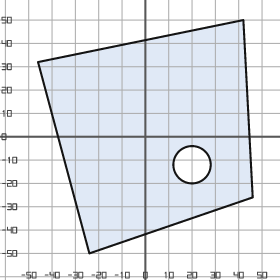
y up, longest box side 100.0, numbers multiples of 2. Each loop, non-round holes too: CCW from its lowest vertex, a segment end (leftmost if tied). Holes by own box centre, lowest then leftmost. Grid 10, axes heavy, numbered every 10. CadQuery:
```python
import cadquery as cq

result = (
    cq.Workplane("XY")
    .moveTo(-24.0, -50.0)
    .lineTo(46.0, -26.0)
    .lineTo(42.0, 50.0)
    .lineTo(-46.0, 32.0)
    .close()
    .moveTo(20.0, -12.0)
    .circle(8.0)
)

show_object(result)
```